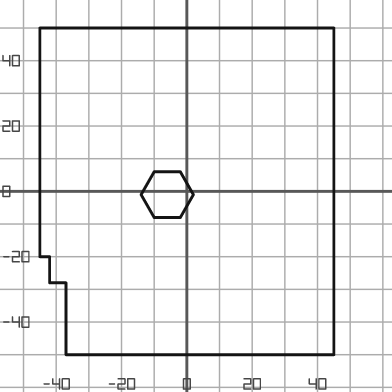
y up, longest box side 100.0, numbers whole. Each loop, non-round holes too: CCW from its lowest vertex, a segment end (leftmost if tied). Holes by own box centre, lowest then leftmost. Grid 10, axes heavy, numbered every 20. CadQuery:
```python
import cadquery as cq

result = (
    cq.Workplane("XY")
    .moveTo(-37.0, -50.0)
    .lineTo(45.0, -50.0)
    .lineTo(45.0, 50.0)
    .lineTo(-45.0, 50.0)
    .lineTo(-45.0, -20.0)
    .lineTo(-42.0, -20.0)
    .lineTo(-42.0, -28.0)
    .lineTo(-37.0, -28.0)
    .close()
    .moveTo(-10.0, -8.0)
    .lineTo(-2.0, -8.0)
    .lineTo(2.0, -1.0)
    .lineTo(-2.0, 6.0)
    .lineTo(-10.0, 6.0)
    .lineTo(-14.0, -1.0)
    .close()
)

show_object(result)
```